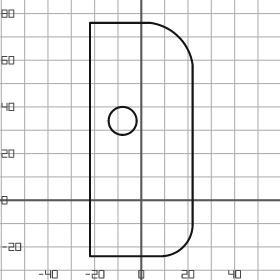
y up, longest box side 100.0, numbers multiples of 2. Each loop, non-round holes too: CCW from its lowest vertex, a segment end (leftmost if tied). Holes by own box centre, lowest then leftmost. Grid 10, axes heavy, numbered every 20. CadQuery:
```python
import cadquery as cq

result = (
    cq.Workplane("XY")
    .moveTo(-22.0, -24.0)
    .lineTo(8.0, -24.0)
    .threePointArc((18.0, -20.0), (22.0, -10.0))
    .lineTo(22.0, 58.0)
    .threePointArc((16.0, 70.0), (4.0, 76.0))
    .lineTo(-22.0, 76.0)
    .close()
    .moveTo(-8.0, 34.0)
    .circle(6.0)
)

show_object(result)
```